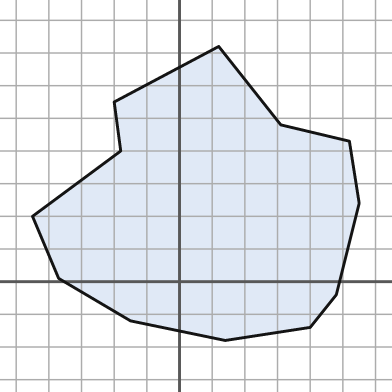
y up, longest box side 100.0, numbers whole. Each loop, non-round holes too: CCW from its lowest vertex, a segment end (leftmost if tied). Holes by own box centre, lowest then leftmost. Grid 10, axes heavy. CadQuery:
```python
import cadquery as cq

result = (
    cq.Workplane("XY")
    .moveTo(14.0, -18.0)
    .lineTo(40.0, -14.0)
    .lineTo(48.0, -4.0)
    .lineTo(55.0, 24.0)
    .lineTo(52.0, 43.0)
    .lineTo(31.0, 48.0)
    .lineTo(12.0, 72.0)
    .lineTo(-20.0, 55.0)
    .lineTo(-18.0, 40.0)
    .lineTo(-45.0, 20.0)
    .lineTo(-37.0, 1.0)
    .lineTo(-15.0, -12.0)
    .close()
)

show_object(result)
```